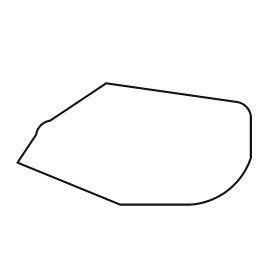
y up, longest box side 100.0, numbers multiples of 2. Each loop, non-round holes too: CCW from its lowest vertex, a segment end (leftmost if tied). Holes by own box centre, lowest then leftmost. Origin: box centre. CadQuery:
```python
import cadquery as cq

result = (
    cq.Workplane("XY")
    .moveTo(-6.0, -26.0)
    .lineTo(24.0, -26.0)
    .threePointArc((40.0, -20.0), (50.0, -6.0))
    .lineTo(50.0, 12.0)
    .threePointArc((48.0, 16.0), (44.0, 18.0))
    .lineTo(-12.0, 26.0)
    .lineTo(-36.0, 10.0)
    .threePointArc((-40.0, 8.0), (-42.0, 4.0))
    .lineTo(-50.0, -8.0)
    .close()
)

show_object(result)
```